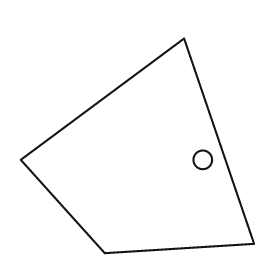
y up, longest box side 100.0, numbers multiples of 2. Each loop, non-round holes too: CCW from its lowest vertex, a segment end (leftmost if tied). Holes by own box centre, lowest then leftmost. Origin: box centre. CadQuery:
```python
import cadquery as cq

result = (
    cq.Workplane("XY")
    .moveTo(-14.0, -46.0)
    .lineTo(50.0, -42.0)
    .lineTo(20.0, 46.0)
    .lineTo(-50.0, -6.0)
    .close()
    .moveTo(28.0, -6.0)
    .circle(4.0)
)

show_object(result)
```